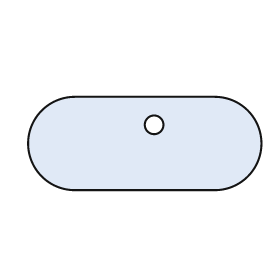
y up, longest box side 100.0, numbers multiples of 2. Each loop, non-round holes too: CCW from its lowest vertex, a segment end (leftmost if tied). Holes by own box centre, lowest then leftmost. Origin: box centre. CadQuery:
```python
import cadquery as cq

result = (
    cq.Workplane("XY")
    .moveTo(-30.0, -20.0)
    .lineTo(30.0, -20.0)
    .threePointArc((50.0, 0.0), (30.0, 20.0))
    .lineTo(-30.0, 20.0)
    .threePointArc((-50.0, 0.0), (-30.0, -20.0))
    .close()
    .moveTo(4.0, 8.0)
    .circle(4.0)
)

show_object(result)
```